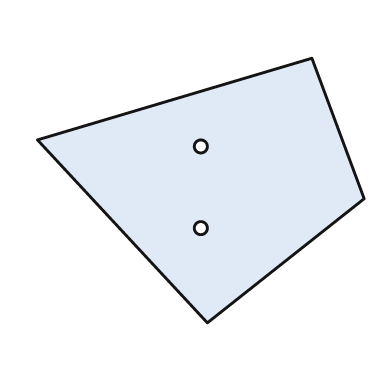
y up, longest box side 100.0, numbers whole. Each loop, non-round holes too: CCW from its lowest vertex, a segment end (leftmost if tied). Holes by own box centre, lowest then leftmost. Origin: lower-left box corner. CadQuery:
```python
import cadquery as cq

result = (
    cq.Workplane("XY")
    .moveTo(52.0, 0.0)
    .lineTo(100.0, 38.0)
    .lineTo(84.0, 81.0)
    .lineTo(0.0, 56.0)
    .close()
    .moveTo(50.0, 29.0)
    .circle(2.0)
    .moveTo(50.0, 54.0)
    .circle(2.0)
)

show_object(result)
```